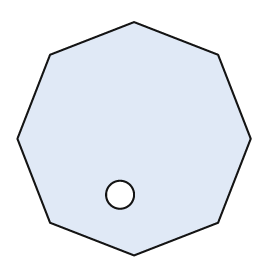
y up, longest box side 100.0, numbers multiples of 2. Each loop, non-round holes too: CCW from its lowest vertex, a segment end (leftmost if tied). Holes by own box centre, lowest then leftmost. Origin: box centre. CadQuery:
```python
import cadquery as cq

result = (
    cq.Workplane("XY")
    .moveTo(0.0, -50.0)
    .lineTo(36.0, -36.0)
    .lineTo(50.0, 0.0)
    .lineTo(36.0, 36.0)
    .lineTo(0.0, 50.0)
    .lineTo(-36.0, 36.0)
    .lineTo(-50.0, 0.0)
    .lineTo(-36.0, -36.0)
    .close()
    .moveTo(-6.0, -24.0)
    .circle(6.0)
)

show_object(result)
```